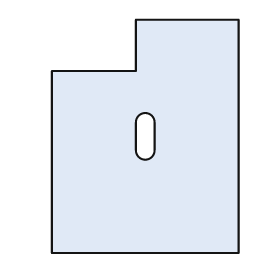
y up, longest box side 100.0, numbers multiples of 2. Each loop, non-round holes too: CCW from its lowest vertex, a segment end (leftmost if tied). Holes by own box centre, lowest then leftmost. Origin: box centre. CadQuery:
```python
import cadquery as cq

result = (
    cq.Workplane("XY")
    .moveTo(-40.0, -50.0)
    .lineTo(40.0, -50.0)
    .lineTo(40.0, 50.0)
    .lineTo(-4.0, 50.0)
    .lineTo(-4.0, 28.0)
    .lineTo(-40.0, 28.0)
    .close()
    .moveTo(-4.0, -6.0)
    .threePointArc((0.0, -10.0), (4.0, -6.0))
    .lineTo(4.0, 6.0)
    .threePointArc((0.0, 10.0), (-4.0, 6.0))
    .close()
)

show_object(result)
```